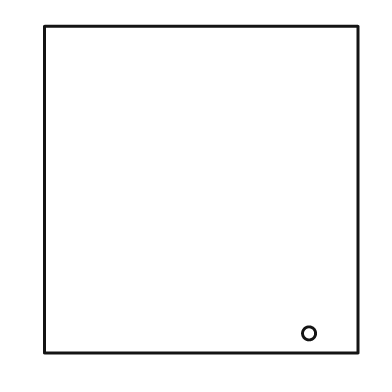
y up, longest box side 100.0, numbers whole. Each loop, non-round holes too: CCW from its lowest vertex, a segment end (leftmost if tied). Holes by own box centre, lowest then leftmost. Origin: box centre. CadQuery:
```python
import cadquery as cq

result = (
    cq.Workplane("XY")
    .moveTo(-48.0, -50.0)
    .lineTo(48.0, -50.0)
    .lineTo(48.0, 50.0)
    .lineTo(-48.0, 50.0)
    .close()
    .moveTo(33.0, -44.0)
    .circle(2.0)
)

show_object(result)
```